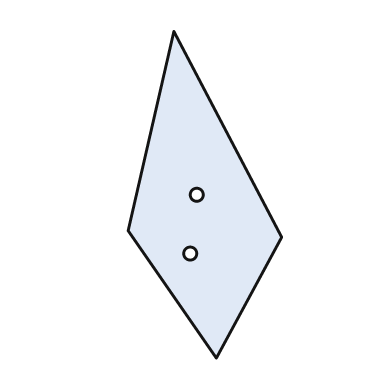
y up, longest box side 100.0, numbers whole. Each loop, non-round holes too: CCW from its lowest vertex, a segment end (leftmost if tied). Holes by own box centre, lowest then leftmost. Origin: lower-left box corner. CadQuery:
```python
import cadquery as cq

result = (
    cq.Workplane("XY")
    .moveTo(27.0, 0.0)
    .lineTo(47.0, 37.0)
    .lineTo(14.0, 100.0)
    .lineTo(0.0, 39.0)
    .close()
    .moveTo(19.0, 32.0)
    .circle(2.0)
    .moveTo(21.0, 50.0)
    .circle(2.0)
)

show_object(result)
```